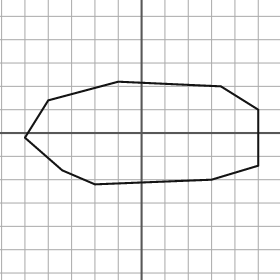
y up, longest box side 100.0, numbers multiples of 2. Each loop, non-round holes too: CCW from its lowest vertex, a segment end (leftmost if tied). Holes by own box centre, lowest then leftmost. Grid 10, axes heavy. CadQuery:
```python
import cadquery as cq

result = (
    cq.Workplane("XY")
    .moveTo(-20.0, -22.0)
    .lineTo(30.0, -20.0)
    .lineTo(50.0, -14.0)
    .lineTo(50.0, 10.0)
    .lineTo(34.0, 20.0)
    .lineTo(-10.0, 22.0)
    .lineTo(-40.0, 14.0)
    .lineTo(-50.0, -2.0)
    .lineTo(-34.0, -16.0)
    .close()
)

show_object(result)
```